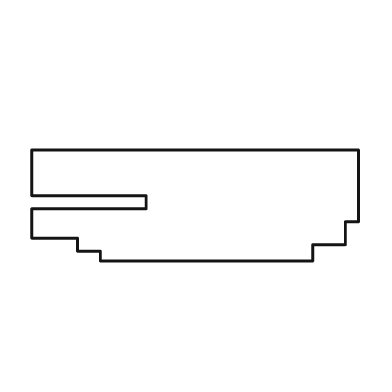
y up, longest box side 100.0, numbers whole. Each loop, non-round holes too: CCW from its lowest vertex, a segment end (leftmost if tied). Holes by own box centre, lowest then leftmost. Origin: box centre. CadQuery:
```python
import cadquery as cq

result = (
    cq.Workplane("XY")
    .moveTo(-29.0, -17.0)
    .lineTo(36.0, -17.0)
    .lineTo(36.0, -12.0)
    .lineTo(46.0, -12.0)
    .lineTo(46.0, -5.0)
    .lineTo(50.0, -5.0)
    .lineTo(50.0, 17.0)
    .lineTo(-50.0, 17.0)
    .lineTo(-50.0, 3.0)
    .lineTo(-15.0, 3.0)
    .lineTo(-15.0, -1.0)
    .lineTo(-50.0, -1.0)
    .lineTo(-50.0, -10.0)
    .lineTo(-36.0, -10.0)
    .lineTo(-36.0, -14.0)
    .lineTo(-29.0, -14.0)
    .close()
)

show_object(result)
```